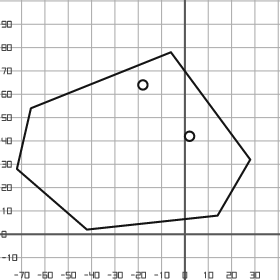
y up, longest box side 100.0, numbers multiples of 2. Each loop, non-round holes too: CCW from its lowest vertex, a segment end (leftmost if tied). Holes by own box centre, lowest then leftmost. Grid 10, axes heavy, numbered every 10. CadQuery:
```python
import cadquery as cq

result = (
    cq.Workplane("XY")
    .moveTo(-42.0, 2.0)
    .lineTo(14.0, 8.0)
    .lineTo(28.0, 32.0)
    .lineTo(-6.0, 78.0)
    .lineTo(-66.0, 54.0)
    .lineTo(-72.0, 28.0)
    .close()
    .moveTo(2.0, 42.0)
    .circle(2.0)
    .moveTo(-18.0, 64.0)
    .circle(2.0)
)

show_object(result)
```